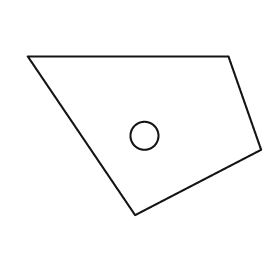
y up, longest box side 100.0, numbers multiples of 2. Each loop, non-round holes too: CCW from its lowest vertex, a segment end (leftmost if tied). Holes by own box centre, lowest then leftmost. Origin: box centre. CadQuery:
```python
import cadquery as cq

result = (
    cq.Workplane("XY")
    .moveTo(-4.0, -34.0)
    .lineTo(50.0, -6.0)
    .lineTo(36.0, 34.0)
    .lineTo(-50.0, 34.0)
    .close()
    .moveTo(0.0, 0.0)
    .circle(6.0)
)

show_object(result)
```